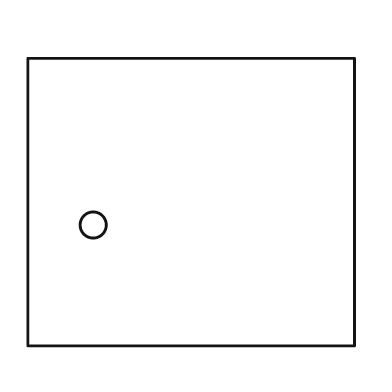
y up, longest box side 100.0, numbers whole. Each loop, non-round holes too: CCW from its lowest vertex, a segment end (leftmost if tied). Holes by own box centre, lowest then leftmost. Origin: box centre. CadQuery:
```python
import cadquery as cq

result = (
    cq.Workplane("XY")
    .moveTo(-50.0, -44.0)
    .lineTo(50.0, -44.0)
    .lineTo(50.0, 44.0)
    .lineTo(-50.0, 44.0)
    .close()
    .moveTo(-30.0, -7.0)
    .circle(4.0)
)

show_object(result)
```